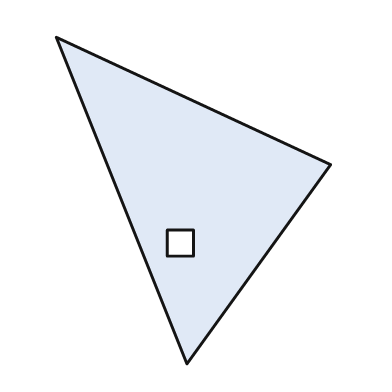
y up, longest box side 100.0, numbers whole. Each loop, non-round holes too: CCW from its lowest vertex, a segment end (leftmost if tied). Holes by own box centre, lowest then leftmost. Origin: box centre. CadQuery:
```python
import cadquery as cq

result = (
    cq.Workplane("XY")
    .moveTo(-2.0, -50.0)
    .lineTo(42.0, 11.0)
    .lineTo(-42.0, 50.0)
    .close()
    .moveTo(-8.0, -17.0)
    .lineTo(0.0, -17.0)
    .lineTo(0.0, -9.0)
    .lineTo(-8.0, -9.0)
    .close()
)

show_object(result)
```